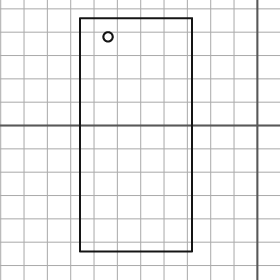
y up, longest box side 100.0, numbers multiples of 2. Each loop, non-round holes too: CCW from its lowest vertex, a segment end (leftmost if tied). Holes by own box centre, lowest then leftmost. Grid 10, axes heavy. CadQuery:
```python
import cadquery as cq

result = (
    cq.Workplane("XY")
    .moveTo(-76.0, -54.0)
    .lineTo(-28.0, -54.0)
    .lineTo(-28.0, 46.0)
    .lineTo(-76.0, 46.0)
    .close()
    .moveTo(-64.0, 38.0)
    .circle(2.0)
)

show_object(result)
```